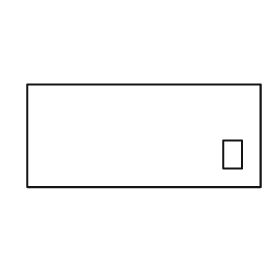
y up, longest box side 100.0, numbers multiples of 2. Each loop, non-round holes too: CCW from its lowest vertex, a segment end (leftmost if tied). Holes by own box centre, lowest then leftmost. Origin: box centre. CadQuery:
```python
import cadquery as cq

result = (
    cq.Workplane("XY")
    .moveTo(-50.0, -22.0)
    .lineTo(50.0, -22.0)
    .lineTo(50.0, 22.0)
    .lineTo(-50.0, 22.0)
    .close()
    .moveTo(34.0, -14.0)
    .lineTo(42.0, -14.0)
    .lineTo(42.0, -2.0)
    .lineTo(34.0, -2.0)
    .close()
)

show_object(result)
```